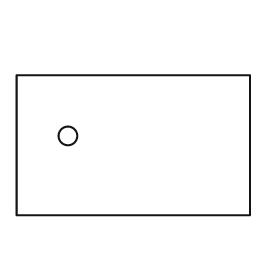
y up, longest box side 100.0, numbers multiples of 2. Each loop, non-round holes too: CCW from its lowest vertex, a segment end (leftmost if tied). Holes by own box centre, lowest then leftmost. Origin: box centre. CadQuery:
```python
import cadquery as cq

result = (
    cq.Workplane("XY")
    .moveTo(-50.0, -30.0)
    .lineTo(50.0, -30.0)
    .lineTo(50.0, 30.0)
    .lineTo(-50.0, 30.0)
    .close()
    .moveTo(-28.0, 4.0)
    .circle(4.0)
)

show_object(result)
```